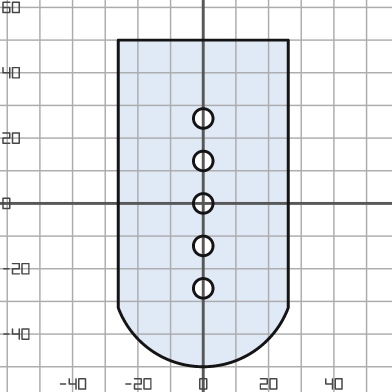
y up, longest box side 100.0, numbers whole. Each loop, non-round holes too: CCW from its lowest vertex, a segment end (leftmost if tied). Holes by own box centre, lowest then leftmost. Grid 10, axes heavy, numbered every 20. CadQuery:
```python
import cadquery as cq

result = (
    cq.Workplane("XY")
    .moveTo(-26.0, -32.0)
    .threePointArc((0.0, -50.0), (26.0, -32.0))
    .lineTo(26.0, 50.0)
    .lineTo(-26.0, 50.0)
    .close()
    .moveTo(0.0, -26.0)
    .circle(3.0)
    .moveTo(0.0, -13.0)
    .circle(3.0)
    .moveTo(0.0, 0.0)
    .circle(3.0)
    .moveTo(0.0, 13.0)
    .circle(3.0)
    .moveTo(0.0, 26.0)
    .circle(3.0)
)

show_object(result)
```